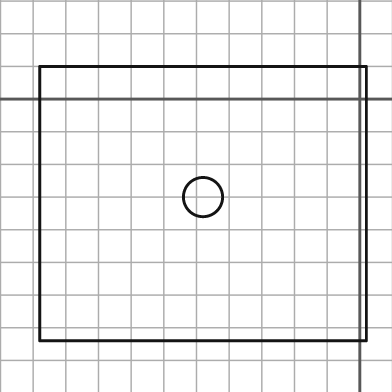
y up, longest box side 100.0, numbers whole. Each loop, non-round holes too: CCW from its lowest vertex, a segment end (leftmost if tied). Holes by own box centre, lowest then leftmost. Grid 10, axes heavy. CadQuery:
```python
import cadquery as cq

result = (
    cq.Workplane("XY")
    .moveTo(-98.0, -74.0)
    .lineTo(2.0, -74.0)
    .lineTo(2.0, 10.0)
    .lineTo(-98.0, 10.0)
    .close()
    .moveTo(-48.0, -30.0)
    .circle(6.0)
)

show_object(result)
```